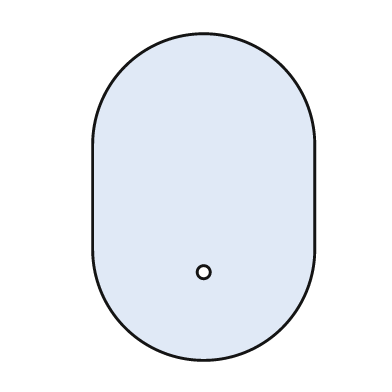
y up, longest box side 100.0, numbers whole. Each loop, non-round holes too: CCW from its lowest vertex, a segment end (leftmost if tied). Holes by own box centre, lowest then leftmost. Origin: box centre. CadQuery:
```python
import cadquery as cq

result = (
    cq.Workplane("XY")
    .moveTo(-34.0, -16.0)
    .threePointArc((0.0, -50.0), (34.0, -16.0))
    .lineTo(34.0, 16.0)
    .threePointArc((0.0, 50.0), (-34.0, 16.0))
    .close()
    .moveTo(0.0, -23.0)
    .circle(2.0)
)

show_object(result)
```